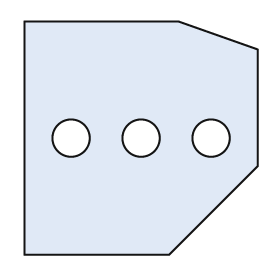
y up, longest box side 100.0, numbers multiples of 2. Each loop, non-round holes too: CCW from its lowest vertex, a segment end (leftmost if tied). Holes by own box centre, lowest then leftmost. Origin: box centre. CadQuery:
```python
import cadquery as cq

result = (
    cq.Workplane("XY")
    .moveTo(-50.0, -50.0)
    .lineTo(12.0, -50.0)
    .lineTo(50.0, -12.0)
    .lineTo(50.0, 38.0)
    .lineTo(16.0, 50.0)
    .lineTo(-50.0, 50.0)
    .close()
    .moveTo(-30.0, 0.0)
    .circle(8.0)
    .moveTo(0.0, 0.0)
    .circle(8.0)
    .moveTo(30.0, 0.0)
    .circle(8.0)
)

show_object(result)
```